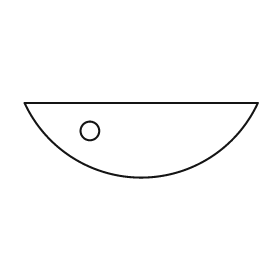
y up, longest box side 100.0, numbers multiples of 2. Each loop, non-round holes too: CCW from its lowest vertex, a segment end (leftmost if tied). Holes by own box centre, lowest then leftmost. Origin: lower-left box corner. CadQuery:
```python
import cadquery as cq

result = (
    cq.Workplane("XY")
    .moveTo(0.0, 32.0)
    .threePointArc((50.0, 0.0), (100.0, 32.0))
    .close()
    .moveTo(28.0, 20.0)
    .circle(4.0)
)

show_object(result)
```